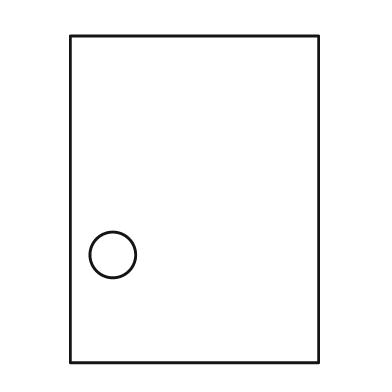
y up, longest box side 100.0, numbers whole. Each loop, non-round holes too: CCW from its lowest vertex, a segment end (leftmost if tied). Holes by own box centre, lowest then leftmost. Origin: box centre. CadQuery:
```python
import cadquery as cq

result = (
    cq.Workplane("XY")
    .moveTo(-38.0, -50.0)
    .lineTo(38.0, -50.0)
    .lineTo(38.0, 50.0)
    .lineTo(-38.0, 50.0)
    .close()
    .moveTo(-25.0, -17.0)
    .circle(7.0)
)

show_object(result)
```